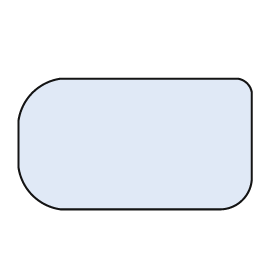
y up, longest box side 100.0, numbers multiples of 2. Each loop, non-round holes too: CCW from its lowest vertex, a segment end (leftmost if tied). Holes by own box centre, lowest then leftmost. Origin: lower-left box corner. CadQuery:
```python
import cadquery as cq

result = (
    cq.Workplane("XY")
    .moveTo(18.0, 0.0)
    .lineTo(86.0, 0.0)
    .threePointArc((96.0, 4.0), (100.0, 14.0))
    .lineTo(100.0, 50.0)
    .threePointArc((98.0, 54.0), (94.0, 56.0))
    .lineTo(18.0, 56.0)
    .threePointArc((6.0, 50.0), (0.0, 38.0))
    .lineTo(0.0, 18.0)
    .threePointArc((6.0, 6.0), (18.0, 0.0))
    .close()
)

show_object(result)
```